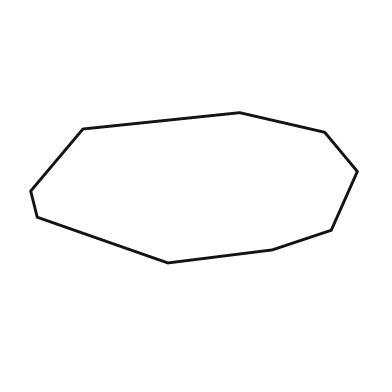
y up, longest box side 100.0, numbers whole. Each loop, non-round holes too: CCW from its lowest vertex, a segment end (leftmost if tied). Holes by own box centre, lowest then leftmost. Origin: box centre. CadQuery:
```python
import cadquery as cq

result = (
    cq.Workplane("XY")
    .moveTo(-8.0, -23.0)
    .lineTo(24.0, -19.0)
    .lineTo(42.0, -13.0)
    .lineTo(50.0, 5.0)
    .lineTo(40.0, 17.0)
    .lineTo(14.0, 23.0)
    .lineTo(-34.0, 18.0)
    .lineTo(-50.0, -1.0)
    .lineTo(-48.0, -9.0)
    .close()
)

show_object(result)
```